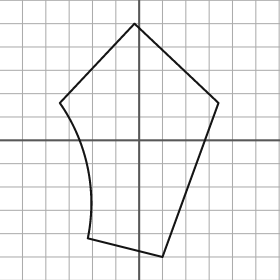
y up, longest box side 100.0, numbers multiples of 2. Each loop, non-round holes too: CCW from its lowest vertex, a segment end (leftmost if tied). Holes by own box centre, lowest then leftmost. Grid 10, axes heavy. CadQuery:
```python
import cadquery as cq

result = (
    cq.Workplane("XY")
    .moveTo(10.0, -50.0)
    .lineTo(34.0, 16.0)
    .lineTo(-2.0, 50.0)
    .lineTo(-34.0, 16.0)
    .threePointArc((-22.0, -12.0), (-22.0, -42.0))
    .close()
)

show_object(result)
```